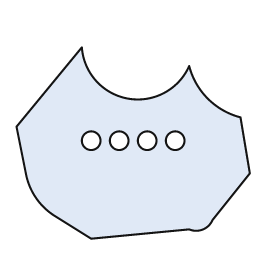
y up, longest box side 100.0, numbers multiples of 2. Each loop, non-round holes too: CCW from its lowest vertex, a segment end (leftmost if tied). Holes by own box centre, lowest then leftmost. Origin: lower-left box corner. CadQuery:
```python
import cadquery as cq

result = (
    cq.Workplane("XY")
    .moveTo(32.0, 0.0)
    .lineTo(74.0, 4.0)
    .threePointArc((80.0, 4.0), (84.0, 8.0))
    .lineTo(100.0, 28.0)
    .lineTo(96.0, 52.0)
    .threePointArc((82.0, 60.0), (74.0, 74.0))
    .threePointArc((48.0, 60.0), (28.0, 82.0))
    .lineTo(0.0, 48.0)
    .lineTo(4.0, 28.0)
    .threePointArc((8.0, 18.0), (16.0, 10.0))
    .close()
    .moveTo(32.0, 42.0)
    .circle(4.0)
    .moveTo(44.0, 42.0)
    .circle(4.0)
    .moveTo(56.0, 42.0)
    .circle(4.0)
    .moveTo(68.0, 42.0)
    .circle(4.0)
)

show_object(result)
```